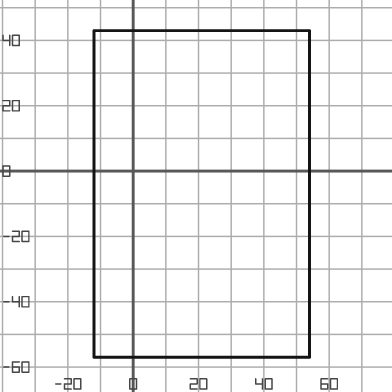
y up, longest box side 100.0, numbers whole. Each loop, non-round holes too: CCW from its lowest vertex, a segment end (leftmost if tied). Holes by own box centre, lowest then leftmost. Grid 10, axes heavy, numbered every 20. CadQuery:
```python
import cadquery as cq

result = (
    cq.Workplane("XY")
    .moveTo(-12.0, -57.0)
    .lineTo(54.0, -57.0)
    .lineTo(54.0, 43.0)
    .lineTo(-12.0, 43.0)
    .close()
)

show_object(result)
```